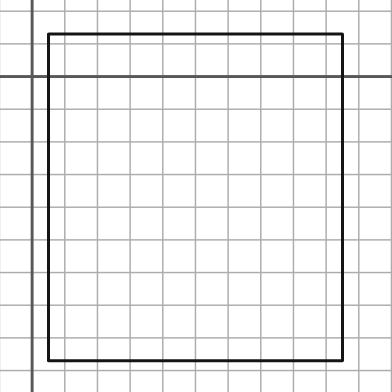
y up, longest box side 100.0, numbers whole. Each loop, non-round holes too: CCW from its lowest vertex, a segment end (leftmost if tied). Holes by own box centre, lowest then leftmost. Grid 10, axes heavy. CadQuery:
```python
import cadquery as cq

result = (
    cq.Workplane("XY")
    .moveTo(5.0, -87.0)
    .lineTo(95.0, -87.0)
    .lineTo(95.0, 13.0)
    .lineTo(5.0, 13.0)
    .close()
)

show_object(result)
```